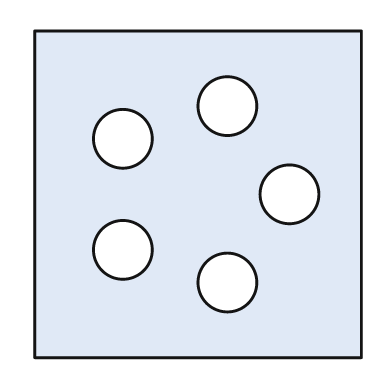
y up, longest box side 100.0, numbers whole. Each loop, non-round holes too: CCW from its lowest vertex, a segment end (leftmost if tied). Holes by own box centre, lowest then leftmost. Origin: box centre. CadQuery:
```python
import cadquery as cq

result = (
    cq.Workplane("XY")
    .moveTo(-50.0, -50.0)
    .lineTo(50.0, -50.0)
    .lineTo(50.0, 50.0)
    .lineTo(-50.0, 50.0)
    .close()
    .moveTo(9.0, -27.0)
    .circle(9.0)
    .moveTo(-23.0, -17.0)
    .circle(9.0)
    .moveTo(28.0, 0.0)
    .circle(9.0)
    .moveTo(-23.0, 17.0)
    .circle(9.0)
    .moveTo(9.0, 27.0)
    .circle(9.0)
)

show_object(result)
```